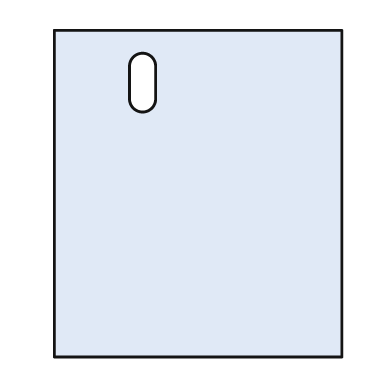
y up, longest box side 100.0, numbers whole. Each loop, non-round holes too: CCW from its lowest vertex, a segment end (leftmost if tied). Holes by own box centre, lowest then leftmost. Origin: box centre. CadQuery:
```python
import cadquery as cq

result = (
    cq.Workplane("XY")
    .moveTo(-44.0, -50.0)
    .lineTo(44.0, -50.0)
    .lineTo(44.0, 50.0)
    .lineTo(-44.0, 50.0)
    .close()
    .moveTo(-21.0, 29.0)
    .threePointArc((-17.0, 25.0), (-13.0, 29.0))
    .lineTo(-13.0, 39.0)
    .threePointArc((-17.0, 43.0), (-21.0, 39.0))
    .close()
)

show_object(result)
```